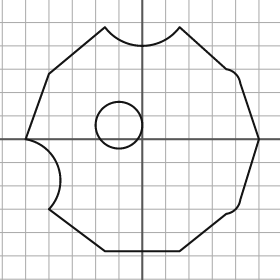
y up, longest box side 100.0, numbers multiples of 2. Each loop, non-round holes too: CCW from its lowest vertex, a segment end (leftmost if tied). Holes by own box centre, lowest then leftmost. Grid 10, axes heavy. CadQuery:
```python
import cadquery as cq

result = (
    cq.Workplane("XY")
    .moveTo(-16.0, -48.0)
    .lineTo(16.0, -48.0)
    .lineTo(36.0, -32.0)
    .threePointArc((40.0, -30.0), (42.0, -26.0))
    .lineTo(50.0, 0.0)
    .lineTo(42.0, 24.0)
    .threePointArc((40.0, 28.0), (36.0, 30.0))
    .lineTo(16.0, 48.0)
    .threePointArc((0.0, 40.0), (-16.0, 48.0))
    .lineTo(-40.0, 28.0)
    .lineTo(-50.0, 0.0)
    .threePointArc((-36.0, -12.0), (-40.0, -30.0))
    .close()
    .moveTo(-10.0, 6.0)
    .circle(10.0)
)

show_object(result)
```